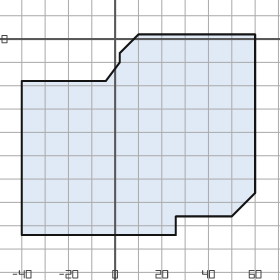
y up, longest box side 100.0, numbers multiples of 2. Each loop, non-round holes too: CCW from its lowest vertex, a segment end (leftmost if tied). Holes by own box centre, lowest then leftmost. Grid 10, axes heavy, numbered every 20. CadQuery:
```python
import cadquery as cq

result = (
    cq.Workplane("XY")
    .moveTo(-40.0, -84.0)
    .lineTo(26.0, -84.0)
    .lineTo(26.0, -76.0)
    .lineTo(50.0, -76.0)
    .lineTo(60.0, -66.0)
    .lineTo(60.0, 2.0)
    .lineTo(10.0, 2.0)
    .lineTo(2.0, -6.0)
    .lineTo(2.0, -10.0)
    .lineTo(-4.0, -18.0)
    .lineTo(-40.0, -18.0)
    .close()
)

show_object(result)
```